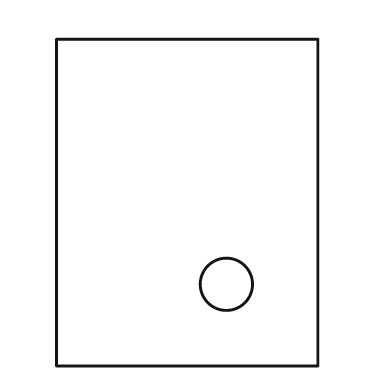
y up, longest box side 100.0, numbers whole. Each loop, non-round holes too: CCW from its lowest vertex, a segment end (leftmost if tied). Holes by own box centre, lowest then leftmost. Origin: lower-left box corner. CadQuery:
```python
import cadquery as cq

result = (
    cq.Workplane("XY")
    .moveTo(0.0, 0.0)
    .lineTo(80.0, 0.0)
    .lineTo(80.0, 100.0)
    .lineTo(0.0, 100.0)
    .close()
    .moveTo(52.0, 25.0)
    .circle(8.0)
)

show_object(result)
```